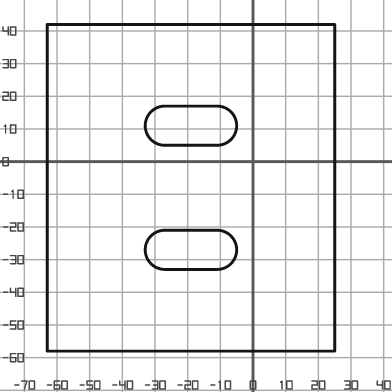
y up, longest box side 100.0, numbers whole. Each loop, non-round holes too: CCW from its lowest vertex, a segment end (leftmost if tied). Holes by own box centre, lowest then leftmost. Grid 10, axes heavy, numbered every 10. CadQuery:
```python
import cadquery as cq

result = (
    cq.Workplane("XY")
    .moveTo(-63.0, -58.0)
    .lineTo(25.0, -58.0)
    .lineTo(25.0, 42.0)
    .lineTo(-63.0, 42.0)
    .close()
    .moveTo(-27.0, -33.0)
    .lineTo(-11.0, -33.0)
    .threePointArc((-5.0, -27.0), (-11.0, -21.0))
    .lineTo(-27.0, -21.0)
    .threePointArc((-33.0, -27.0), (-27.0, -33.0))
    .close()
    .moveTo(-27.0, 5.0)
    .lineTo(-11.0, 5.0)
    .threePointArc((-5.0, 11.0), (-11.0, 17.0))
    .lineTo(-27.0, 17.0)
    .threePointArc((-33.0, 11.0), (-27.0, 5.0))
    .close()
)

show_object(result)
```